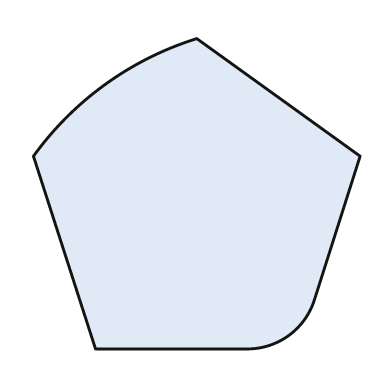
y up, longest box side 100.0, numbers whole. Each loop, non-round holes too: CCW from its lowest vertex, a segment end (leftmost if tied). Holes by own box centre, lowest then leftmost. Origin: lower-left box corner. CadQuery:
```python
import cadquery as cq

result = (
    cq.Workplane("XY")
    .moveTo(19.0, 0.0)
    .lineTo(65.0, 0.0)
    .threePointArc((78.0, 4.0), (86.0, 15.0))
    .lineTo(100.0, 59.0)
    .lineTo(50.0, 95.0)
    .threePointArc((22.0, 81.0), (0.0, 59.0))
    .close()
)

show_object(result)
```